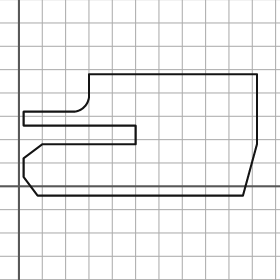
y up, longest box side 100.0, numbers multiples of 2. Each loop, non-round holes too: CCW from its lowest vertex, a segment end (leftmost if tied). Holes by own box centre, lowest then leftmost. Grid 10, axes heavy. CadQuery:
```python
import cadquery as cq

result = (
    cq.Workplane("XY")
    .moveTo(8.0, -4.0)
    .lineTo(96.0, -4.0)
    .lineTo(102.0, 18.0)
    .lineTo(102.0, 48.0)
    .lineTo(30.0, 48.0)
    .lineTo(30.0, 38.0)
    .threePointArc((28.0, 34.0), (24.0, 32.0))
    .lineTo(2.0, 32.0)
    .lineTo(2.0, 26.0)
    .lineTo(50.0, 26.0)
    .lineTo(50.0, 18.0)
    .lineTo(10.0, 18.0)
    .lineTo(2.0, 12.0)
    .lineTo(2.0, 4.0)
    .close()
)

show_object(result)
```